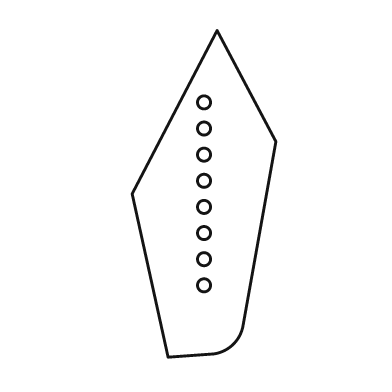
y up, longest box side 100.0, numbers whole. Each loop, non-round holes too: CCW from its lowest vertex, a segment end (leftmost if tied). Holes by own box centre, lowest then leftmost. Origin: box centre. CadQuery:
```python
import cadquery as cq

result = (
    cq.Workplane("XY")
    .moveTo(-11.0, -50.0)
    .lineTo(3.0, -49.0)
    .threePointArc((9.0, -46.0), (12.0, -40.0))
    .lineTo(22.0, 16.0)
    .lineTo(4.0, 50.0)
    .lineTo(-22.0, 0.0)
    .close()
    .moveTo(0.0, -28.0)
    .circle(2.0)
    .moveTo(0.0, -20.0)
    .circle(2.0)
    .moveTo(0.0, -12.0)
    .circle(2.0)
    .moveTo(0.0, -4.0)
    .circle(2.0)
    .moveTo(0.0, 4.0)
    .circle(2.0)
    .moveTo(0.0, 12.0)
    .circle(2.0)
    .moveTo(0.0, 20.0)
    .circle(2.0)
    .moveTo(0.0, 28.0)
    .circle(2.0)
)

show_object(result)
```